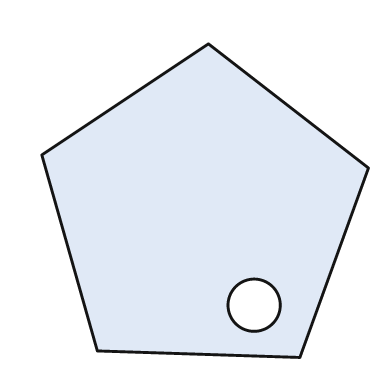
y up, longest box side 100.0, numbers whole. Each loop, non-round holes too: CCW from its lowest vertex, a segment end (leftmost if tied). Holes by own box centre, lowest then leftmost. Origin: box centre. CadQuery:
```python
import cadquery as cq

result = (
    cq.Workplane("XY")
    .moveTo(29.0, -48.0)
    .lineTo(50.0, 10.0)
    .lineTo(1.0, 48.0)
    .lineTo(-50.0, 14.0)
    .lineTo(-33.0, -46.0)
    .close()
    .moveTo(15.0, -32.0)
    .circle(8.0)
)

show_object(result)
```